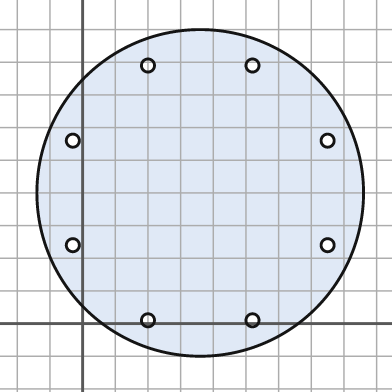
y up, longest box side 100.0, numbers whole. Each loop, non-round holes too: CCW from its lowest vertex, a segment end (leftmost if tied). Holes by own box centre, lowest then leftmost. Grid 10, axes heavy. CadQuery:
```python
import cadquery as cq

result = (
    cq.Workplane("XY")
    .moveTo(36.0, 40.0)
    .circle(50.0)
    .moveTo(20.0, 1.0)
    .circle(2.0)
    .moveTo(52.0, 1.0)
    .circle(2.0)
    .moveTo(-3.0, 24.0)
    .circle(2.0)
    .moveTo(75.0, 24.0)
    .circle(2.0)
    .moveTo(-3.0, 56.0)
    .circle(2.0)
    .moveTo(75.0, 56.0)
    .circle(2.0)
    .moveTo(20.0, 79.0)
    .circle(2.0)
    .moveTo(52.0, 79.0)
    .circle(2.0)
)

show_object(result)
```